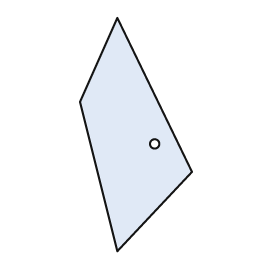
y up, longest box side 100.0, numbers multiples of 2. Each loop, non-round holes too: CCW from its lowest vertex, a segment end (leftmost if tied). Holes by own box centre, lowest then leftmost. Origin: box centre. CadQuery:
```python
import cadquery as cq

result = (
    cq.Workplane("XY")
    .moveTo(-8.0, -50.0)
    .lineTo(24.0, -16.0)
    .lineTo(-8.0, 50.0)
    .lineTo(-24.0, 14.0)
    .close()
    .moveTo(8.0, -4.0)
    .circle(2.0)
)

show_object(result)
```